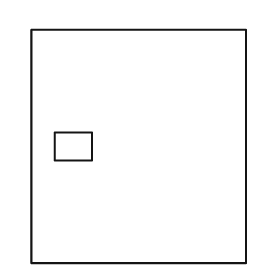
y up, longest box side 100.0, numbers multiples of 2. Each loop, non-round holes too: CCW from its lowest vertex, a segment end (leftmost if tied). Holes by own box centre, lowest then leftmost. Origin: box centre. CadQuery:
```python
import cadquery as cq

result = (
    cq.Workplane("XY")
    .moveTo(-46.0, -50.0)
    .lineTo(46.0, -50.0)
    .lineTo(46.0, 50.0)
    .lineTo(-46.0, 50.0)
    .close()
    .moveTo(-36.0, -6.0)
    .lineTo(-20.0, -6.0)
    .lineTo(-20.0, 6.0)
    .lineTo(-36.0, 6.0)
    .close()
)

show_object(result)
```